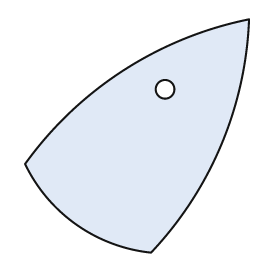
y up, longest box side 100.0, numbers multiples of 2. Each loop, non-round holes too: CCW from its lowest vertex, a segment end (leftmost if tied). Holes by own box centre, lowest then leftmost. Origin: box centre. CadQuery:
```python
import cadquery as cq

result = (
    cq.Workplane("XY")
    .moveTo(6.0, -50.0)
    .threePointArc((36.0, -4.0), (48.0, 50.0))
    .threePointArc((-6.0, 28.0), (-48.0, -12.0))
    .threePointArc((-26.0, -38.0), (6.0, -50.0))
    .close()
    .moveTo(12.0, 20.0)
    .circle(4.0)
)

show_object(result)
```